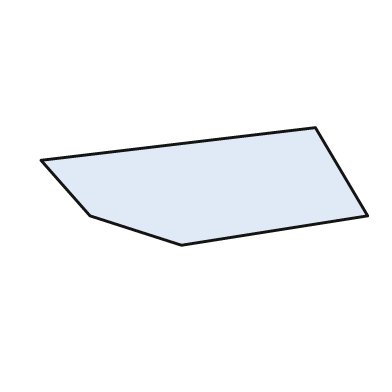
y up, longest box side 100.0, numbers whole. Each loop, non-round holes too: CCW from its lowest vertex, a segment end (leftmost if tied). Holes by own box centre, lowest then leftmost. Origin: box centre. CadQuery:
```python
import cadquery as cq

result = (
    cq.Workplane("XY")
    .moveTo(-7.0, -18.0)
    .lineTo(50.0, -9.0)
    .lineTo(34.0, 18.0)
    .lineTo(-50.0, 8.0)
    .lineTo(-35.0, -9.0)
    .close()
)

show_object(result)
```